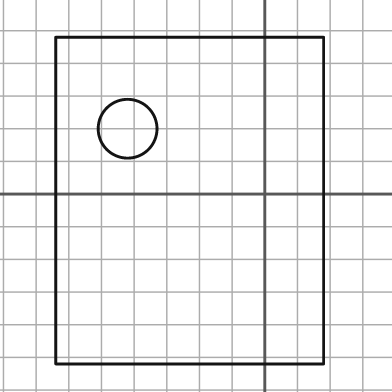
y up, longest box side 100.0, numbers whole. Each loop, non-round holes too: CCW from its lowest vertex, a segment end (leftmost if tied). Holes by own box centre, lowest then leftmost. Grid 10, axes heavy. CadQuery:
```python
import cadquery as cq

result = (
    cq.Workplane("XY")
    .moveTo(-64.0, -52.0)
    .lineTo(18.0, -52.0)
    .lineTo(18.0, 48.0)
    .lineTo(-64.0, 48.0)
    .close()
    .moveTo(-42.0, 20.0)
    .circle(9.0)
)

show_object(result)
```